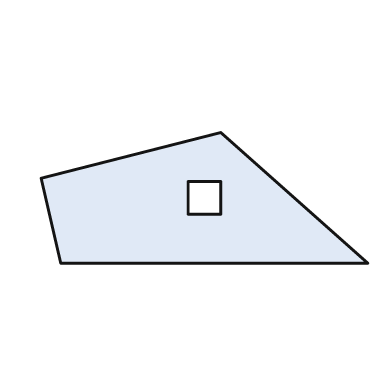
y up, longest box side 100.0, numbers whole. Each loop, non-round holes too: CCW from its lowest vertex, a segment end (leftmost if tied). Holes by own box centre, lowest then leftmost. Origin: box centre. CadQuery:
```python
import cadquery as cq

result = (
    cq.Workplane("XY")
    .moveTo(-44.0, -20.0)
    .lineTo(50.0, -20.0)
    .lineTo(5.0, 20.0)
    .lineTo(-50.0, 6.0)
    .close()
    .moveTo(-5.0, -5.0)
    .lineTo(5.0, -5.0)
    .lineTo(5.0, 5.0)
    .lineTo(-5.0, 5.0)
    .close()
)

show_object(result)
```